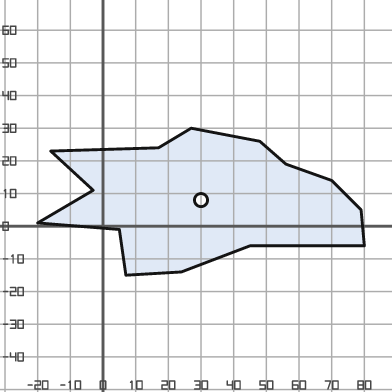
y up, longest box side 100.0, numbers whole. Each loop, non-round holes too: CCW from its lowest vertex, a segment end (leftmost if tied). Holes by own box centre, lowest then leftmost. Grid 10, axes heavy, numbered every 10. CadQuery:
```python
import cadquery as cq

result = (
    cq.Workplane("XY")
    .moveTo(7.0, -15.0)
    .lineTo(24.0, -14.0)
    .lineTo(45.0, -6.0)
    .lineTo(80.0, -6.0)
    .lineTo(79.0, 5.0)
    .lineTo(70.0, 14.0)
    .lineTo(56.0, 19.0)
    .lineTo(48.0, 26.0)
    .lineTo(27.0, 30.0)
    .lineTo(17.0, 24.0)
    .lineTo(-16.0, 23.0)
    .lineTo(-3.0, 11.0)
    .lineTo(-20.0, 1.0)
    .lineTo(5.0, -1.0)
    .close()
    .moveTo(30.0, 8.0)
    .circle(2.0)
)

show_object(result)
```